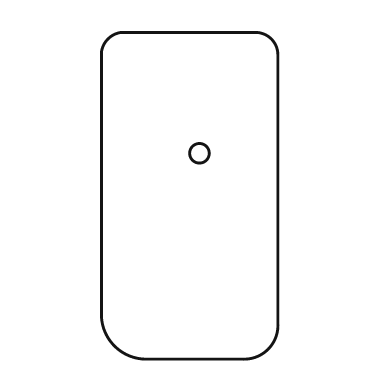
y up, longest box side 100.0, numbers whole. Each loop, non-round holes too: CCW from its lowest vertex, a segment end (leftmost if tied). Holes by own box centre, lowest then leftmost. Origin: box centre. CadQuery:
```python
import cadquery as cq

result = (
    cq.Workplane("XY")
    .moveTo(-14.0, -50.0)
    .lineTo(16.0, -50.0)
    .threePointArc((24.0, -47.0), (27.0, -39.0))
    .lineTo(27.0, 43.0)
    .threePointArc((25.0, 48.0), (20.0, 50.0))
    .lineTo(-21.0, 50.0)
    .threePointArc((-25.0, 48.0), (-27.0, 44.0))
    .lineTo(-27.0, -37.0)
    .threePointArc((-23.0, -46.0), (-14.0, -50.0))
    .close()
    .moveTo(3.0, 13.0)
    .circle(3.0)
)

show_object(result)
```